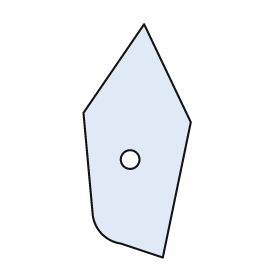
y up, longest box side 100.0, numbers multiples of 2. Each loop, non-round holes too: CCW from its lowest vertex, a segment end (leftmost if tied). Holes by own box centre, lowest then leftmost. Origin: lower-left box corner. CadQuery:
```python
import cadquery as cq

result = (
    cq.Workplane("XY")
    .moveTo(34.0, 0.0)
    .lineTo(46.0, 58.0)
    .lineTo(26.0, 100.0)
    .lineTo(0.0, 62.0)
    .lineTo(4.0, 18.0)
    .threePointArc((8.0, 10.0), (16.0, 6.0))
    .close()
    .moveTo(20.0, 42.0)
    .circle(4.0)
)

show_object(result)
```